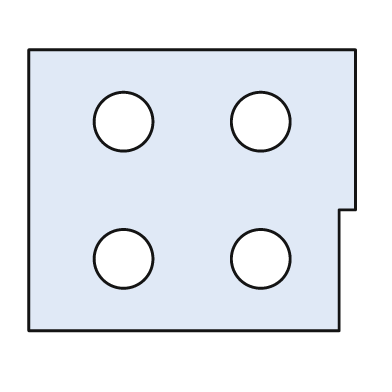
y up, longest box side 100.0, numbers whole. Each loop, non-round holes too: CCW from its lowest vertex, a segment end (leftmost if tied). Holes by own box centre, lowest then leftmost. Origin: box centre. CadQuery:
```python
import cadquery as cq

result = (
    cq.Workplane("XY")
    .moveTo(-50.0, -43.0)
    .lineTo(45.0, -43.0)
    .lineTo(45.0, -6.0)
    .lineTo(50.0, -6.0)
    .lineTo(50.0, 43.0)
    .lineTo(-50.0, 43.0)
    .close()
    .moveTo(-21.0, -21.0)
    .circle(9.0)
    .moveTo(21.0, -21.0)
    .circle(9.0)
    .moveTo(-21.0, 21.0)
    .circle(9.0)
    .moveTo(21.0, 21.0)
    .circle(9.0)
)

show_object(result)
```